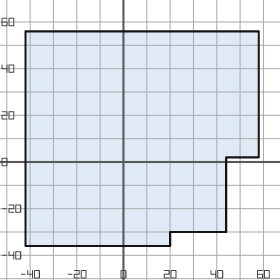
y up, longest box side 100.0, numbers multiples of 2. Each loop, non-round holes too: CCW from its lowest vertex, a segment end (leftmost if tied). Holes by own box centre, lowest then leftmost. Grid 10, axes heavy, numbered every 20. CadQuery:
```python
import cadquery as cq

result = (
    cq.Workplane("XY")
    .moveTo(-42.0, -36.0)
    .lineTo(20.0, -36.0)
    .lineTo(20.0, -30.0)
    .lineTo(44.0, -30.0)
    .lineTo(44.0, 2.0)
    .lineTo(58.0, 2.0)
    .lineTo(58.0, 56.0)
    .lineTo(-42.0, 56.0)
    .close()
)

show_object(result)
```